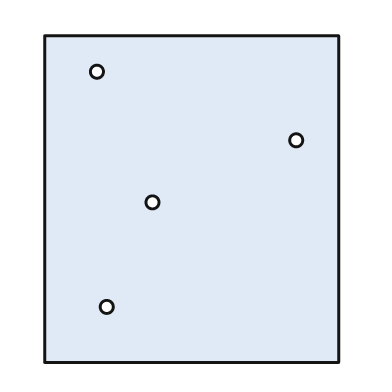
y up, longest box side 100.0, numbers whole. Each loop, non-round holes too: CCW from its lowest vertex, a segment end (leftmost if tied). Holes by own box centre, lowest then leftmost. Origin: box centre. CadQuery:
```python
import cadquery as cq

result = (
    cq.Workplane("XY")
    .moveTo(-45.0, -50.0)
    .lineTo(45.0, -50.0)
    .lineTo(45.0, 50.0)
    .lineTo(-45.0, 50.0)
    .close()
    .moveTo(-26.0, -33.0)
    .circle(2.0)
    .moveTo(-12.0, -1.0)
    .circle(2.0)
    .moveTo(32.0, 18.0)
    .circle(2.0)
    .moveTo(-29.0, 39.0)
    .circle(2.0)
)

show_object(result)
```